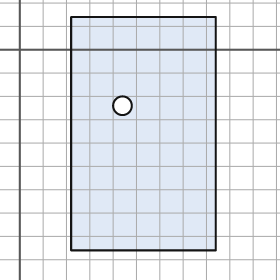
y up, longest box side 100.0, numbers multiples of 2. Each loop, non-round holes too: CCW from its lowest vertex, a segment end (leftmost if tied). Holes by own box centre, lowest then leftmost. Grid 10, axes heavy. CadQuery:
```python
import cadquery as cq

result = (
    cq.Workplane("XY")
    .moveTo(22.0, -86.0)
    .lineTo(84.0, -86.0)
    .lineTo(84.0, 14.0)
    .lineTo(22.0, 14.0)
    .close()
    .moveTo(44.0, -24.0)
    .circle(4.0)
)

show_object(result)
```